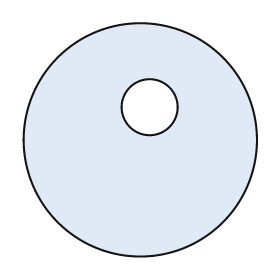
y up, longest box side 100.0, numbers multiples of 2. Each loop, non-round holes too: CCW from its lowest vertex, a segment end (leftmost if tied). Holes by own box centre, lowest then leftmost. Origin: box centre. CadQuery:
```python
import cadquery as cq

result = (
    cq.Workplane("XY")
    .moveTo(0.0, 0.0)
    .circle(50.0)
    .moveTo(4.0, 14.0)
    .circle(12.0)
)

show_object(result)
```